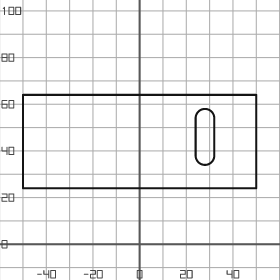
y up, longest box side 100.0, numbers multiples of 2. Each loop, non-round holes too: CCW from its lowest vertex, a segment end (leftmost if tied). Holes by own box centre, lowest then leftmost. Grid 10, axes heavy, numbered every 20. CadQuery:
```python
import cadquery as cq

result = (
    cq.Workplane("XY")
    .moveTo(-50.0, 24.0)
    .lineTo(50.0, 24.0)
    .lineTo(50.0, 64.0)
    .lineTo(-50.0, 64.0)
    .close()
    .moveTo(24.0, 38.0)
    .threePointArc((28.0, 34.0), (32.0, 38.0))
    .lineTo(32.0, 54.0)
    .threePointArc((28.0, 58.0), (24.0, 54.0))
    .close()
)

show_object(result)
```